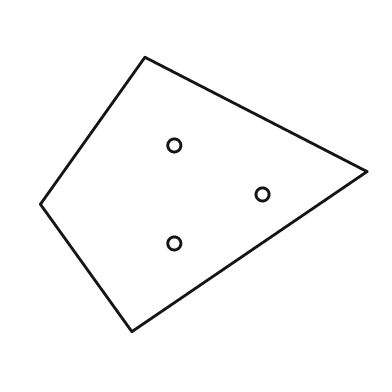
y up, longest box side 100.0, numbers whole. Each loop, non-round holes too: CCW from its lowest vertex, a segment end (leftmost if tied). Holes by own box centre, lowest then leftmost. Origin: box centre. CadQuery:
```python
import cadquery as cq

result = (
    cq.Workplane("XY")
    .moveTo(-22.0, -42.0)
    .lineTo(50.0, 7.0)
    .lineTo(-18.0, 42.0)
    .lineTo(-50.0, -3.0)
    .close()
    .moveTo(-9.0, -15.0)
    .circle(2.0)
    .moveTo(18.0, 0.0)
    .circle(2.0)
    .moveTo(-9.0, 15.0)
    .circle(2.0)
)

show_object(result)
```